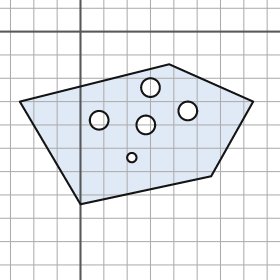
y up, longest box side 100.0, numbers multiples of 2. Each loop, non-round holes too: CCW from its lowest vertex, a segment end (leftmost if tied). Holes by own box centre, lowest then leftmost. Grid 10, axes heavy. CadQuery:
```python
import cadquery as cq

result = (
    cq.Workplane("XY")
    .moveTo(0.0, -74.0)
    .lineTo(56.0, -62.0)
    .lineTo(74.0, -30.0)
    .lineTo(38.0, -14.0)
    .lineTo(-26.0, -30.0)
    .close()
    .moveTo(22.0, -54.0)
    .circle(2.0)
    .moveTo(28.0, -40.0)
    .circle(4.0)
    .moveTo(8.0, -38.0)
    .circle(4.0)
    .moveTo(46.0, -34.0)
    .circle(4.0)
    .moveTo(30.0, -24.0)
    .circle(4.0)
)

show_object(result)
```